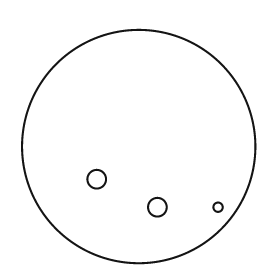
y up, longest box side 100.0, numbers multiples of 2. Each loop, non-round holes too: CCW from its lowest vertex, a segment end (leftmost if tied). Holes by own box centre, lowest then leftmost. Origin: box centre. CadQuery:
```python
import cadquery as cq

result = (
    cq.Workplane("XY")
    .moveTo(0.0, 0.0)
    .circle(50.0)
    .moveTo(8.0, -26.0)
    .circle(4.0)
    .moveTo(34.0, -26.0)
    .circle(2.0)
    .moveTo(-18.0, -14.0)
    .circle(4.0)
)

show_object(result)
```